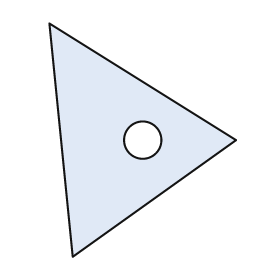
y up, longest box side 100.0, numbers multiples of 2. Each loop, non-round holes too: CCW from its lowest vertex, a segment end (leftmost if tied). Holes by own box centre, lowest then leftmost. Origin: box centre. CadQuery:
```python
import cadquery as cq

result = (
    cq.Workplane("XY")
    .moveTo(-30.0, -50.0)
    .lineTo(40.0, 0.0)
    .lineTo(-40.0, 50.0)
    .close()
    .moveTo(0.0, 0.0)
    .circle(8.0)
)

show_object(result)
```